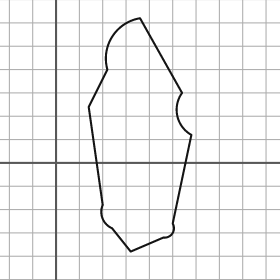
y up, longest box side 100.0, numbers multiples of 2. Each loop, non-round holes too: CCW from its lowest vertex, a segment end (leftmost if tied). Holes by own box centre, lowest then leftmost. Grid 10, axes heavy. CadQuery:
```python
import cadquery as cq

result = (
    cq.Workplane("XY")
    .moveTo(32.0, -38.0)
    .lineTo(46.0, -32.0)
    .threePointArc((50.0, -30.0), (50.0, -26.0))
    .lineTo(58.0, 12.0)
    .threePointArc((52.0, 20.0), (54.0, 30.0))
    .lineTo(36.0, 62.0)
    .threePointArc((24.0, 54.0), (22.0, 40.0))
    .lineTo(14.0, 24.0)
    .lineTo(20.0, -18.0)
    .threePointArc((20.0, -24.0), (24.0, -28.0))
    .close()
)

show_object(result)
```